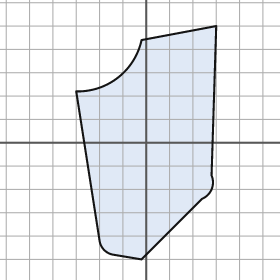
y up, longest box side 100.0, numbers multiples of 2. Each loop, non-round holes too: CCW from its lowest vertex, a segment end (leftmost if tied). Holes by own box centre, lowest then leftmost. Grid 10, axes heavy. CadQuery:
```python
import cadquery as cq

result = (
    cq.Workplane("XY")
    .moveTo(-2.0, -50.0)
    .lineTo(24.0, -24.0)
    .threePointArc((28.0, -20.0), (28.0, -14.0))
    .lineTo(30.0, 50.0)
    .lineTo(-2.0, 44.0)
    .threePointArc((-12.0, 28.0), (-30.0, 22.0))
    .lineTo(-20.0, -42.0)
    .threePointArc((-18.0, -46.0), (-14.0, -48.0))
    .close()
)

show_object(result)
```